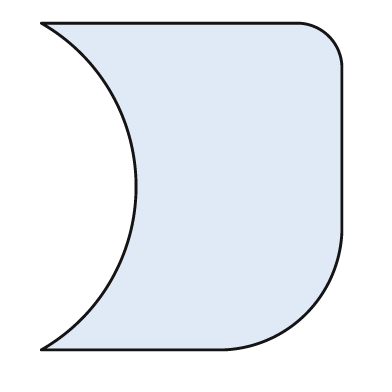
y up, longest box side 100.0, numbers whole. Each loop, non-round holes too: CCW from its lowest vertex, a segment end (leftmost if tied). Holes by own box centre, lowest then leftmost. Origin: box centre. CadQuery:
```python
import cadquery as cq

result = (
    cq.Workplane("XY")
    .moveTo(-46.0, -50.0)
    .lineTo(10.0, -50.0)
    .threePointArc((35.0, -39.0), (46.0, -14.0))
    .lineTo(46.0, 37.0)
    .threePointArc((42.0, 46.0), (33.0, 50.0))
    .lineTo(-46.0, 50.0)
    .threePointArc((-17.0, 0.0), (-46.0, -50.0))
    .close()
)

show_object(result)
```